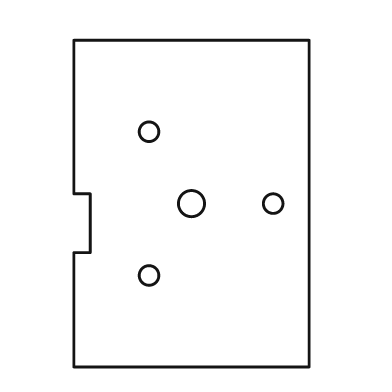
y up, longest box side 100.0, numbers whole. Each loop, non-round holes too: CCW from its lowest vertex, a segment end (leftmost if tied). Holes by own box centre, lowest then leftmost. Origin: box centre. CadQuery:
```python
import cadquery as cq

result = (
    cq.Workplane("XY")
    .moveTo(-36.0, -50.0)
    .lineTo(36.0, -50.0)
    .lineTo(36.0, 50.0)
    .lineTo(-36.0, 50.0)
    .lineTo(-36.0, 3.0)
    .lineTo(-31.0, 3.0)
    .lineTo(-31.0, -15.0)
    .lineTo(-36.0, -15.0)
    .close()
    .moveTo(-13.0, -22.0)
    .circle(3.0)
    .moveTo(0.0, 0.0)
    .circle(4.0)
    .moveTo(25.0, 0.0)
    .circle(3.0)
    .moveTo(-13.0, 22.0)
    .circle(3.0)
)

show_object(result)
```